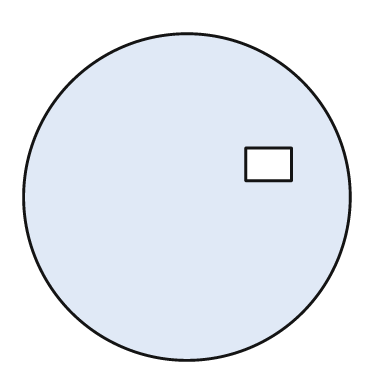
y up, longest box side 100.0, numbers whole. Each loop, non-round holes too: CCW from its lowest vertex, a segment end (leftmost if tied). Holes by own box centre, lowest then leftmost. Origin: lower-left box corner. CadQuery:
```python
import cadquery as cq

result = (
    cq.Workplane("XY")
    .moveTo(50.0, 50.0)
    .circle(50.0)
    .moveTo(68.0, 55.0)
    .lineTo(82.0, 55.0)
    .lineTo(82.0, 65.0)
    .lineTo(68.0, 65.0)
    .close()
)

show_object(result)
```